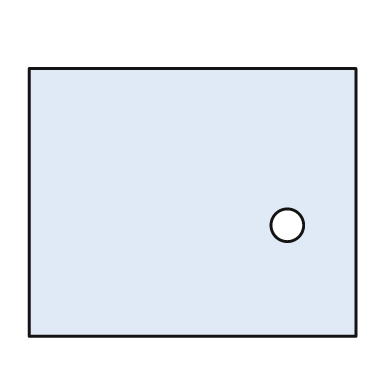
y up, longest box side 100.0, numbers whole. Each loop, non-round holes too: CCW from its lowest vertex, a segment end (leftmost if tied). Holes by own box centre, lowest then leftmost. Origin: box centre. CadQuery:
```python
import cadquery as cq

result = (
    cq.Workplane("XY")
    .moveTo(-50.0, -41.0)
    .lineTo(50.0, -41.0)
    .lineTo(50.0, 41.0)
    .lineTo(-50.0, 41.0)
    .close()
    .moveTo(29.0, -7.0)
    .circle(5.0)
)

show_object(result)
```